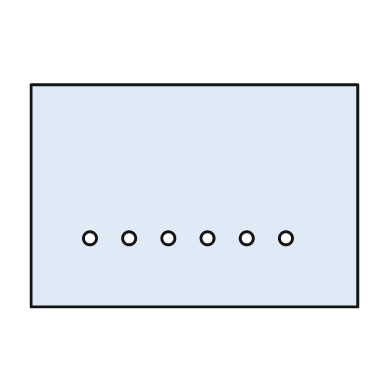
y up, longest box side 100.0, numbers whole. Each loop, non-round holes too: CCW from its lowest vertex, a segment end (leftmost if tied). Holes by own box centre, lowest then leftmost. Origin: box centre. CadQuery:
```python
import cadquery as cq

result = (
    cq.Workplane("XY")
    .moveTo(-50.0, -34.0)
    .lineTo(50.0, -34.0)
    .lineTo(50.0, 34.0)
    .lineTo(-50.0, 34.0)
    .close()
    .moveTo(-32.0, -13.0)
    .circle(2.0)
    .moveTo(-20.0, -13.0)
    .circle(2.0)
    .moveTo(-8.0, -13.0)
    .circle(2.0)
    .moveTo(4.0, -13.0)
    .circle(2.0)
    .moveTo(16.0, -13.0)
    .circle(2.0)
    .moveTo(28.0, -13.0)
    .circle(2.0)
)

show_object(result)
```